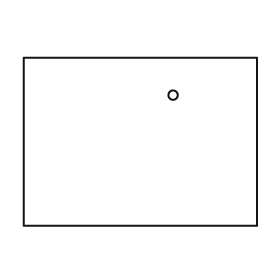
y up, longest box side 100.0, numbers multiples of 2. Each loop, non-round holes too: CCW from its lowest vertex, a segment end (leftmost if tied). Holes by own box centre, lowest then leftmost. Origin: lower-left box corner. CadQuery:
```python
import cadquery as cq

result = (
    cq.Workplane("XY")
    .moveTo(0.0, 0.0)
    .lineTo(100.0, 0.0)
    .lineTo(100.0, 72.0)
    .lineTo(0.0, 72.0)
    .close()
    .moveTo(64.0, 56.0)
    .circle(2.0)
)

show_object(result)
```